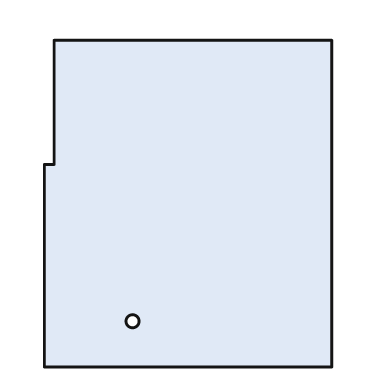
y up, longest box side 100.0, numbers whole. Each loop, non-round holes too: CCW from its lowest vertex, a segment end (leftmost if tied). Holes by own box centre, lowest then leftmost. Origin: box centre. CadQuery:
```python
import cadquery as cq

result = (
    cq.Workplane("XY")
    .moveTo(-44.0, -50.0)
    .lineTo(44.0, -50.0)
    .lineTo(44.0, 50.0)
    .lineTo(-41.0, 50.0)
    .lineTo(-41.0, 12.0)
    .lineTo(-44.0, 12.0)
    .close()
    .moveTo(-17.0, -36.0)
    .circle(2.0)
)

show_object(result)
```